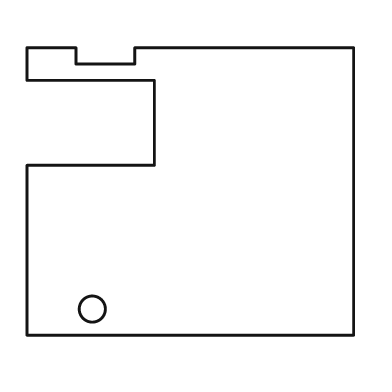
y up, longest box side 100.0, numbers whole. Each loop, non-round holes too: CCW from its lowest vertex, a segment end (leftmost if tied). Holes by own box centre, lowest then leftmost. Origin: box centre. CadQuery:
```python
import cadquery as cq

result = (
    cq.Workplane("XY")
    .moveTo(-50.0, -44.0)
    .lineTo(50.0, -44.0)
    .lineTo(50.0, 44.0)
    .lineTo(-17.0, 44.0)
    .lineTo(-17.0, 39.0)
    .lineTo(-35.0, 39.0)
    .lineTo(-35.0, 44.0)
    .lineTo(-50.0, 44.0)
    .lineTo(-50.0, 34.0)
    .lineTo(-11.0, 34.0)
    .lineTo(-11.0, 8.0)
    .lineTo(-50.0, 8.0)
    .close()
    .moveTo(-30.0, -36.0)
    .circle(4.0)
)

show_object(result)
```